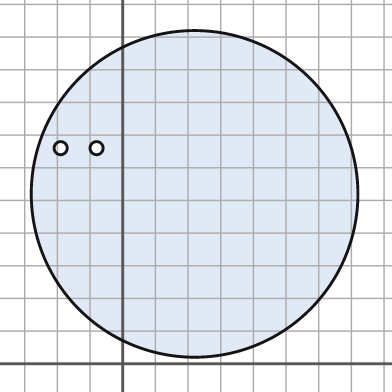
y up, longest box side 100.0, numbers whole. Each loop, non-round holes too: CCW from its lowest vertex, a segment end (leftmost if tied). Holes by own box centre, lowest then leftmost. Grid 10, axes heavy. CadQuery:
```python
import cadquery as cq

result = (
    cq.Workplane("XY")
    .moveTo(22.0, 52.0)
    .circle(50.0)
    .moveTo(-19.0, 66.0)
    .circle(2.0)
    .moveTo(-8.0, 66.0)
    .circle(2.0)
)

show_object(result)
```